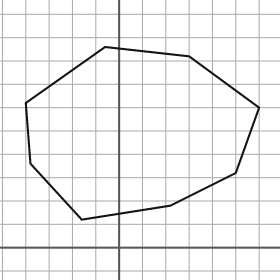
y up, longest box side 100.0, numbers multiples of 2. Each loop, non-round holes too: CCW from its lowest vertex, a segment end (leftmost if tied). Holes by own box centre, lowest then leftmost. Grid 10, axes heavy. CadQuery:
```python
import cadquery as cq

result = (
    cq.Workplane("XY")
    .moveTo(-16.0, 12.0)
    .lineTo(22.0, 18.0)
    .lineTo(50.0, 32.0)
    .lineTo(60.0, 60.0)
    .lineTo(30.0, 82.0)
    .lineTo(-6.0, 86.0)
    .lineTo(-40.0, 62.0)
    .lineTo(-38.0, 36.0)
    .close()
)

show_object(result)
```